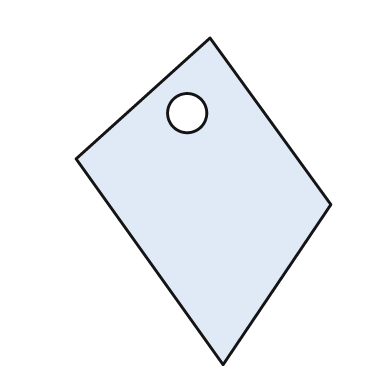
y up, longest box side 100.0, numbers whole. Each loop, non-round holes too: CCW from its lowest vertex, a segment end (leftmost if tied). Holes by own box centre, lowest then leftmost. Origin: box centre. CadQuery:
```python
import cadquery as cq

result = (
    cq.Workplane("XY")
    .moveTo(6.0, -50.0)
    .lineTo(39.0, -1.0)
    .lineTo(2.0, 50.0)
    .lineTo(-39.0, 13.0)
    .close()
    .moveTo(-5.0, 27.0)
    .circle(6.0)
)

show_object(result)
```